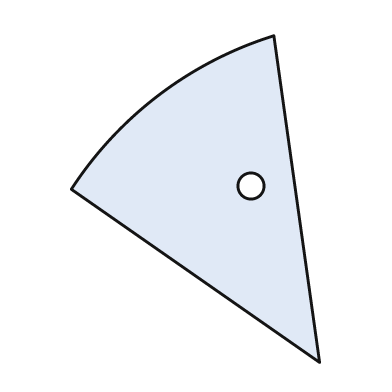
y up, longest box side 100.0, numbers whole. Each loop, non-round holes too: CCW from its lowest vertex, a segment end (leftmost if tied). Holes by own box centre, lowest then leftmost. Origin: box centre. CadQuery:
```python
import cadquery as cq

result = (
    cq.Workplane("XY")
    .moveTo(38.0, -50.0)
    .lineTo(24.0, 50.0)
    .threePointArc((-11.0, 32.0), (-38.0, 3.0))
    .close()
    .moveTo(17.0, 4.0)
    .circle(4.0)
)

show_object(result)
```